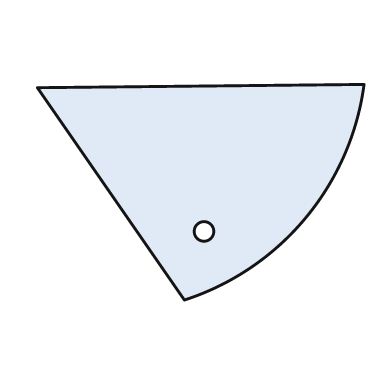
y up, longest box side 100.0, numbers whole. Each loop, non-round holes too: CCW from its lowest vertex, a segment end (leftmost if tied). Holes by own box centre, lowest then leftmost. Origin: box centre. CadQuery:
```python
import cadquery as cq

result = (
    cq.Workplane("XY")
    .moveTo(-5.0, -33.0)
    .threePointArc((32.0, -8.0), (50.0, 33.0))
    .lineTo(-50.0, 32.0)
    .close()
    .moveTo(1.0, -12.0)
    .circle(3.0)
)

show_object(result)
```